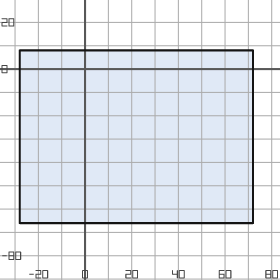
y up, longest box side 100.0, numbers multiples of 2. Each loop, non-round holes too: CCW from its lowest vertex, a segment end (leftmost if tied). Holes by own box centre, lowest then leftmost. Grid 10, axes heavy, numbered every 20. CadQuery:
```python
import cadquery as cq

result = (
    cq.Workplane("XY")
    .moveTo(-28.0, -66.0)
    .lineTo(72.0, -66.0)
    .lineTo(72.0, 8.0)
    .lineTo(-28.0, 8.0)
    .close()
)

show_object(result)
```